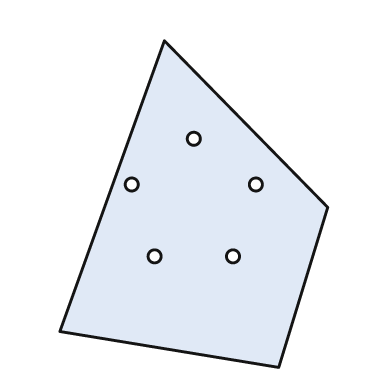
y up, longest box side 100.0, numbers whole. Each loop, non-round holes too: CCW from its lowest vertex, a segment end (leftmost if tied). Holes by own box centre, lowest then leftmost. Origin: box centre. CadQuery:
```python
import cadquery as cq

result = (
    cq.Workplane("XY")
    .moveTo(26.0, -50.0)
    .lineTo(41.0, -1.0)
    .lineTo(-9.0, 50.0)
    .lineTo(-41.0, -39.0)
    .close()
    .moveTo(-12.0, -16.0)
    .circle(2.0)
    .moveTo(12.0, -16.0)
    .circle(2.0)
    .moveTo(-19.0, 6.0)
    .circle(2.0)
    .moveTo(19.0, 6.0)
    .circle(2.0)
    .moveTo(0.0, 20.0)
    .circle(2.0)
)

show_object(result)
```